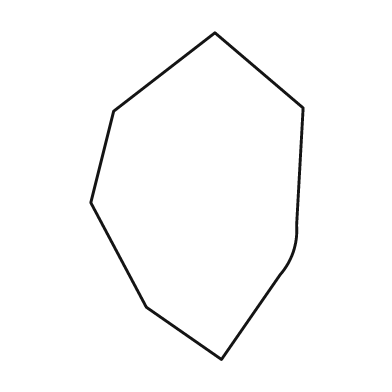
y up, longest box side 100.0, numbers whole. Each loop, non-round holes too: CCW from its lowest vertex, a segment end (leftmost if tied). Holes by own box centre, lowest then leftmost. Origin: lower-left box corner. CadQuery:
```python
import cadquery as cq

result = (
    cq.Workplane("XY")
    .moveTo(40.0, 0.0)
    .lineTo(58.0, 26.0)
    .threePointArc((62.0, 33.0), (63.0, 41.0))
    .lineTo(65.0, 77.0)
    .lineTo(38.0, 100.0)
    .lineTo(7.0, 76.0)
    .lineTo(0.0, 48.0)
    .lineTo(17.0, 16.0)
    .close()
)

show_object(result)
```